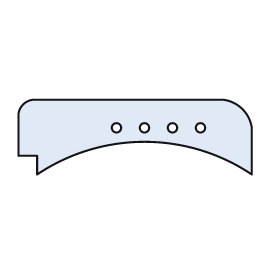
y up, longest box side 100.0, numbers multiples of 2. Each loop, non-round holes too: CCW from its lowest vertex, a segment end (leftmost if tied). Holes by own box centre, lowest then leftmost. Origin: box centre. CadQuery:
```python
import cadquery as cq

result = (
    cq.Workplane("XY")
    .moveTo(-42.0, -16.0)
    .threePointArc((4.0, -2.0), (50.0, -16.0))
    .lineTo(50.0, 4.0)
    .threePointArc((46.0, 12.0), (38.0, 16.0))
    .lineTo(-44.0, 16.0)
    .threePointArc((-48.0, 14.0), (-50.0, 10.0))
    .lineTo(-50.0, -8.0)
    .lineTo(-42.0, -8.0)
    .close()
    .moveTo(-8.0, 4.0)
    .circle(2.0)
    .moveTo(4.0, 4.0)
    .circle(2.0)
    .moveTo(16.0, 4.0)
    .circle(2.0)
    .moveTo(28.0, 4.0)
    .circle(2.0)
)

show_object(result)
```